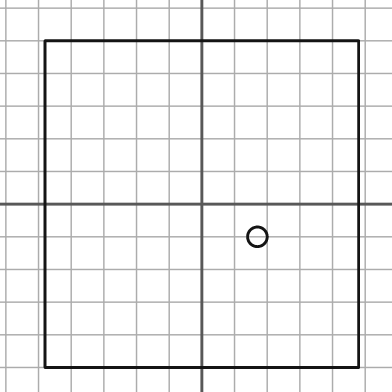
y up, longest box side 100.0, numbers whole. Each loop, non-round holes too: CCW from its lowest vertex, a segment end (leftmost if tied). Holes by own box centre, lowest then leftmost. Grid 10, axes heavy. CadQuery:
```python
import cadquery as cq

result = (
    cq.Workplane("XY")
    .moveTo(-48.0, -50.0)
    .lineTo(48.0, -50.0)
    .lineTo(48.0, 50.0)
    .lineTo(-48.0, 50.0)
    .close()
    .moveTo(17.0, -10.0)
    .circle(3.0)
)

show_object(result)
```